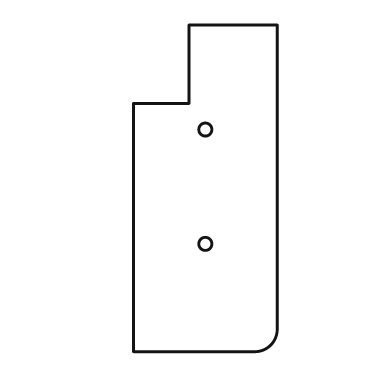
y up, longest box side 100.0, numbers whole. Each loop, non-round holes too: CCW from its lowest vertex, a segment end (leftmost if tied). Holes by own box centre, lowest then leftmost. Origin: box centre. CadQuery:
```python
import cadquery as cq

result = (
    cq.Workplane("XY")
    .moveTo(-22.0, -50.0)
    .lineTo(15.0, -50.0)
    .threePointArc((20.0, -48.0), (22.0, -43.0))
    .lineTo(22.0, 50.0)
    .lineTo(-5.0, 50.0)
    .lineTo(-5.0, 26.0)
    .lineTo(-22.0, 26.0)
    .close()
    .moveTo(0.0, -17.0)
    .circle(2.0)
    .moveTo(0.0, 18.0)
    .circle(2.0)
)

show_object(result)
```